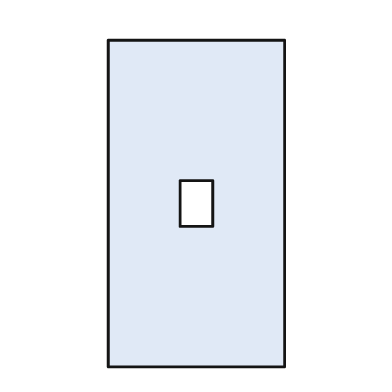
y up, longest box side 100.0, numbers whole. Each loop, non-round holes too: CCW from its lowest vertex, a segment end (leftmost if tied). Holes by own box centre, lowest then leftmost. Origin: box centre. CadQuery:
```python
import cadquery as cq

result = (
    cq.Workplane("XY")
    .moveTo(-27.0, -50.0)
    .lineTo(27.0, -50.0)
    .lineTo(27.0, 50.0)
    .lineTo(-27.0, 50.0)
    .close()
    .moveTo(-5.0, -7.0)
    .lineTo(5.0, -7.0)
    .lineTo(5.0, 7.0)
    .lineTo(-5.0, 7.0)
    .close()
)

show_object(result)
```